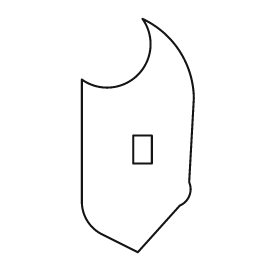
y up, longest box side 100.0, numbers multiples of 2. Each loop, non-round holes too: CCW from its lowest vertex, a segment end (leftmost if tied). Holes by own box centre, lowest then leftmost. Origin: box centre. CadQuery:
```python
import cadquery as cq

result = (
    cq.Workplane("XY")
    .moveTo(0.0, -50.0)
    .lineTo(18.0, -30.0)
    .threePointArc((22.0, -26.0), (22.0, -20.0))
    .lineTo(24.0, 16.0)
    .threePointArc((18.0, 36.0), (2.0, 50.0))
    .threePointArc((0.0, 26.0), (-24.0, 24.0))
    .lineTo(-24.0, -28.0)
    .threePointArc((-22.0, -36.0), (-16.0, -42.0))
    .close()
    .moveTo(-2.0, -12.0)
    .lineTo(6.0, -12.0)
    .lineTo(6.0, 0.0)
    .lineTo(-2.0, 0.0)
    .close()
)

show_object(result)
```